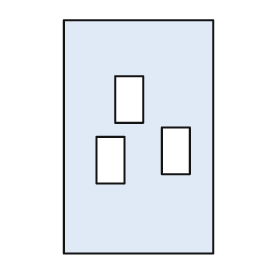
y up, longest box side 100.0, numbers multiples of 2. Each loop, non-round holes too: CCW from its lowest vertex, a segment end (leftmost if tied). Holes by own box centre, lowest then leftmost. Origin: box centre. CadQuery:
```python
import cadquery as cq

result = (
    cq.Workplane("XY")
    .moveTo(-32.0, -50.0)
    .lineTo(32.0, -50.0)
    .lineTo(32.0, 50.0)
    .lineTo(-32.0, 50.0)
    .close()
    .moveTo(-18.0, -20.0)
    .lineTo(-6.0, -20.0)
    .lineTo(-6.0, 0.0)
    .lineTo(-18.0, 0.0)
    .close()
    .moveTo(10.0, -16.0)
    .lineTo(22.0, -16.0)
    .lineTo(22.0, 4.0)
    .lineTo(10.0, 4.0)
    .close()
    .moveTo(-10.0, 6.0)
    .lineTo(2.0, 6.0)
    .lineTo(2.0, 26.0)
    .lineTo(-10.0, 26.0)
    .close()
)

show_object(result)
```